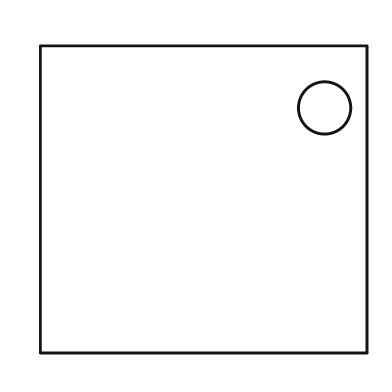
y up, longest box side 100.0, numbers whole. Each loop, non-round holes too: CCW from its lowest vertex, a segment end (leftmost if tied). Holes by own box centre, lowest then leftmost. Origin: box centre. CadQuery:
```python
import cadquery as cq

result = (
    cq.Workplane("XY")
    .moveTo(-50.0, -47.0)
    .lineTo(50.0, -47.0)
    .lineTo(50.0, 47.0)
    .lineTo(-50.0, 47.0)
    .close()
    .moveTo(37.0, 28.0)
    .circle(8.0)
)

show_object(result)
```